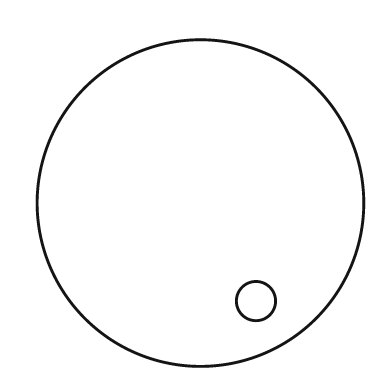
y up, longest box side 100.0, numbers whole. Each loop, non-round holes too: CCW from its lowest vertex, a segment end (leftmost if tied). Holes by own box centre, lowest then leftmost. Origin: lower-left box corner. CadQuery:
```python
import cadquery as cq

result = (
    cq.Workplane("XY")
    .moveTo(50.0, 50.0)
    .circle(50.0)
    .moveTo(67.0, 20.0)
    .circle(6.0)
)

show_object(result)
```